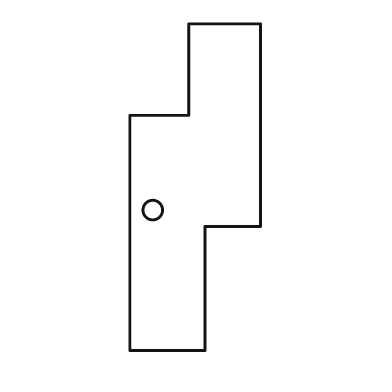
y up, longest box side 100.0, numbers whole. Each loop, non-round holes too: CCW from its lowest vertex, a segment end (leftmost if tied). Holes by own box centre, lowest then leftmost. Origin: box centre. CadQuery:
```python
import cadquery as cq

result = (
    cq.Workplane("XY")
    .moveTo(-20.0, -50.0)
    .lineTo(3.0, -50.0)
    .lineTo(3.0, -12.0)
    .lineTo(20.0, -12.0)
    .lineTo(20.0, 50.0)
    .lineTo(-2.0, 50.0)
    .lineTo(-2.0, 22.0)
    .lineTo(-20.0, 22.0)
    .close()
    .moveTo(-13.0, -7.0)
    .circle(3.0)
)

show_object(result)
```